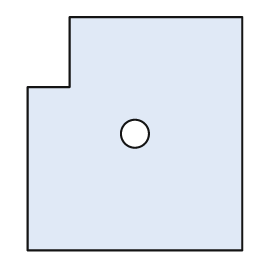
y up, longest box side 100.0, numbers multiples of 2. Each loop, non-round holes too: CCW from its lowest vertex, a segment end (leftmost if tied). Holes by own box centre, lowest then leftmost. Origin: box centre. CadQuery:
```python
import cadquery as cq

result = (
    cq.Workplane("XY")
    .moveTo(-46.0, -50.0)
    .lineTo(46.0, -50.0)
    .lineTo(46.0, 50.0)
    .lineTo(-28.0, 50.0)
    .lineTo(-28.0, 20.0)
    .lineTo(-46.0, 20.0)
    .close()
    .moveTo(0.0, 0.0)
    .circle(6.0)
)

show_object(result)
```